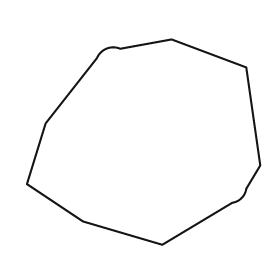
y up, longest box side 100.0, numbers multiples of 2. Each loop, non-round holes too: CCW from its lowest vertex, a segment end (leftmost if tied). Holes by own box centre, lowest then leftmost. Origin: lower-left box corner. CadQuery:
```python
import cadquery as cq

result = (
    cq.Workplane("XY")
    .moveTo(58.0, 0.0)
    .lineTo(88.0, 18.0)
    .threePointArc((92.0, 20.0), (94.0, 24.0))
    .lineTo(100.0, 34.0)
    .lineTo(94.0, 76.0)
    .lineTo(62.0, 88.0)
    .lineTo(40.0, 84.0)
    .threePointArc((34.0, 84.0), (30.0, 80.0))
    .lineTo(8.0, 52.0)
    .lineTo(0.0, 26.0)
    .lineTo(24.0, 10.0)
    .close()
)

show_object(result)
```